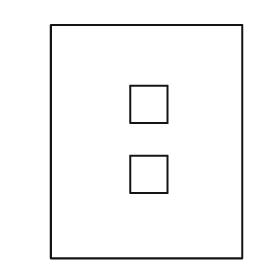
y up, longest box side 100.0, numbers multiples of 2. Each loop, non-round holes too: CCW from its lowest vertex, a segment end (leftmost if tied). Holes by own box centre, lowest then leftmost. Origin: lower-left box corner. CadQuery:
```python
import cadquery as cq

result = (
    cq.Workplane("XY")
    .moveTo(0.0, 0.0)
    .lineTo(82.0, 0.0)
    .lineTo(82.0, 100.0)
    .lineTo(0.0, 100.0)
    .close()
    .moveTo(34.0, 28.0)
    .lineTo(50.0, 28.0)
    .lineTo(50.0, 44.0)
    .lineTo(34.0, 44.0)
    .close()
    .moveTo(34.0, 58.0)
    .lineTo(50.0, 58.0)
    .lineTo(50.0, 74.0)
    .lineTo(34.0, 74.0)
    .close()
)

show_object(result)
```